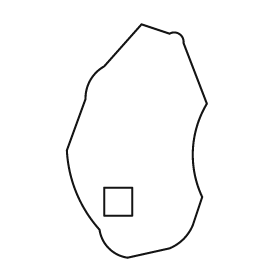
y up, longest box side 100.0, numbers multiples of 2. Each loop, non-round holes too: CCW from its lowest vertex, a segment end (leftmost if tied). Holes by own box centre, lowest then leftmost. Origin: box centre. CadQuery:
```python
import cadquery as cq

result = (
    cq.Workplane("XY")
    .moveTo(-4.0, -50.0)
    .lineTo(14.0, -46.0)
    .threePointArc((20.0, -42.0), (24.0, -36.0))
    .lineTo(28.0, -24.0)
    .threePointArc((24.0, -4.0), (30.0, 16.0))
    .lineTo(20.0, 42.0)
    .threePointArc((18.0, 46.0), (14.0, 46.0))
    .lineTo(2.0, 50.0)
    .lineTo(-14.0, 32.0)
    .threePointArc((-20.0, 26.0), (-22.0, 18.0))
    .lineTo(-30.0, -4.0)
    .threePointArc((-26.0, -22.0), (-16.0, -38.0))
    .threePointArc((-12.0, -46.0), (-4.0, -50.0))
    .close()
    .moveTo(-14.0, -32.0)
    .lineTo(-2.0, -32.0)
    .lineTo(-2.0, -20.0)
    .lineTo(-14.0, -20.0)
    .close()
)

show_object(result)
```